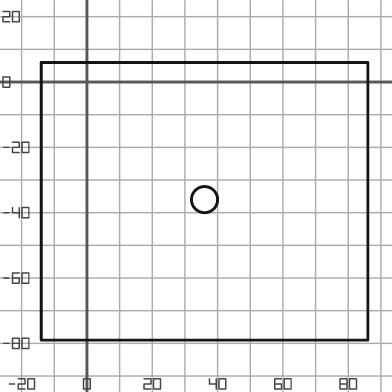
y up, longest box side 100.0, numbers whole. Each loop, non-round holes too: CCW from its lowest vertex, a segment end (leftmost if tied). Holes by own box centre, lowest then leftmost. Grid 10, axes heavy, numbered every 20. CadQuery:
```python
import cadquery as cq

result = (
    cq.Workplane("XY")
    .moveTo(-14.0, -79.0)
    .lineTo(86.0, -79.0)
    .lineTo(86.0, 6.0)
    .lineTo(-14.0, 6.0)
    .close()
    .moveTo(36.0, -36.0)
    .circle(4.0)
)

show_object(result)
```